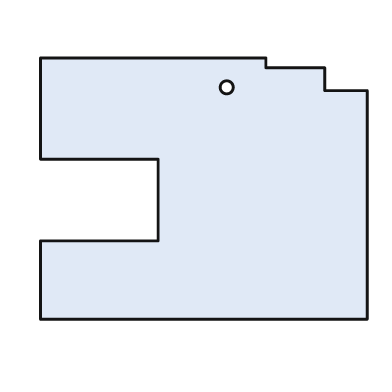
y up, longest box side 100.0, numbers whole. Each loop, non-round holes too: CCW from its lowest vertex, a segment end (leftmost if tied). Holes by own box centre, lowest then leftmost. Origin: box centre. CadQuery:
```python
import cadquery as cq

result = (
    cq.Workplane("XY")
    .moveTo(-50.0, -40.0)
    .lineTo(50.0, -40.0)
    .lineTo(50.0, 30.0)
    .lineTo(37.0, 30.0)
    .lineTo(37.0, 37.0)
    .lineTo(19.0, 37.0)
    .lineTo(19.0, 40.0)
    .lineTo(-50.0, 40.0)
    .lineTo(-50.0, 9.0)
    .lineTo(-14.0, 9.0)
    .lineTo(-14.0, -16.0)
    .lineTo(-50.0, -16.0)
    .close()
    .moveTo(7.0, 31.0)
    .circle(2.0)
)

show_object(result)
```